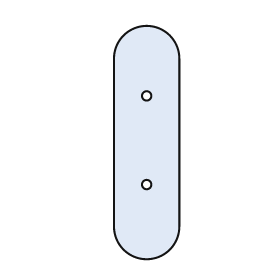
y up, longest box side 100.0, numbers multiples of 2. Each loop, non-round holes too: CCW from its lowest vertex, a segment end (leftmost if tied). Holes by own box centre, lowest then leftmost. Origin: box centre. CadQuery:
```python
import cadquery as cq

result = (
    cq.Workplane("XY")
    .moveTo(-14.0, -36.0)
    .threePointArc((0.0, -50.0), (14.0, -36.0))
    .lineTo(14.0, 36.0)
    .threePointArc((0.0, 50.0), (-14.0, 36.0))
    .close()
    .moveTo(0.0, -18.0)
    .circle(2.0)
    .moveTo(0.0, 20.0)
    .circle(2.0)
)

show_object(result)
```